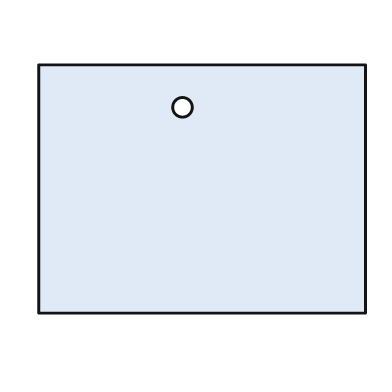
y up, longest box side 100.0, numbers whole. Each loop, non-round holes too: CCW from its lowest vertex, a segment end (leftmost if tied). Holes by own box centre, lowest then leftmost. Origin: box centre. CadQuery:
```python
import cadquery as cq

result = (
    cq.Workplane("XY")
    .moveTo(-50.0, -38.0)
    .lineTo(50.0, -38.0)
    .lineTo(50.0, 38.0)
    .lineTo(-50.0, 38.0)
    .close()
    .moveTo(-6.0, 25.0)
    .circle(3.0)
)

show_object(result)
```